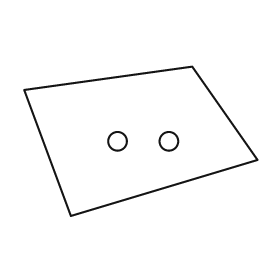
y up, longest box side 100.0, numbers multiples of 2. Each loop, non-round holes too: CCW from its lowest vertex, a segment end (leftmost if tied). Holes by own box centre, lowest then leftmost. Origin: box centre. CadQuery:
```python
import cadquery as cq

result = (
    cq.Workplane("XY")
    .moveTo(-30.0, -32.0)
    .lineTo(50.0, -8.0)
    .lineTo(22.0, 32.0)
    .lineTo(-50.0, 22.0)
    .close()
    .moveTo(-10.0, 0.0)
    .circle(4.0)
    .moveTo(12.0, 0.0)
    .circle(4.0)
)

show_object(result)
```